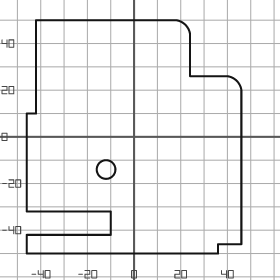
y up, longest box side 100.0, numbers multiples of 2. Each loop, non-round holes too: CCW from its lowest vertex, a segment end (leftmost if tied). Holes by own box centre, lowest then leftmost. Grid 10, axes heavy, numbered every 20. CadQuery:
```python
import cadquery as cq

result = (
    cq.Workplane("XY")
    .moveTo(-46.0, -50.0)
    .lineTo(36.0, -50.0)
    .lineTo(36.0, -46.0)
    .lineTo(46.0, -46.0)
    .lineTo(46.0, 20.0)
    .threePointArc((44.0, 24.0), (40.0, 26.0))
    .lineTo(24.0, 26.0)
    .lineTo(24.0, 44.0)
    .threePointArc((22.0, 48.0), (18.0, 50.0))
    .lineTo(-42.0, 50.0)
    .lineTo(-42.0, 10.0)
    .lineTo(-46.0, 10.0)
    .lineTo(-46.0, -32.0)
    .lineTo(-10.0, -32.0)
    .lineTo(-10.0, -42.0)
    .lineTo(-46.0, -42.0)
    .close()
    .moveTo(-12.0, -14.0)
    .circle(4.0)
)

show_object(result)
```